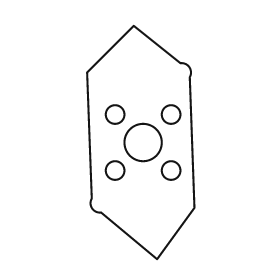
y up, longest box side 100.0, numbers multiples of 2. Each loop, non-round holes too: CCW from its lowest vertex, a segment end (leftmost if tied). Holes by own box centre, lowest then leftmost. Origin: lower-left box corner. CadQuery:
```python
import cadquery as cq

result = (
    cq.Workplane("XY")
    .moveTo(30.0, 0.0)
    .lineTo(46.0, 22.0)
    .lineTo(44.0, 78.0)
    .threePointArc((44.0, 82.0), (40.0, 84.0))
    .lineTo(20.0, 100.0)
    .lineTo(0.0, 80.0)
    .lineTo(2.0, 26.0)
    .threePointArc((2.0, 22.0), (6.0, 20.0))
    .close()
    .moveTo(12.0, 38.0)
    .circle(4.0)
    .moveTo(36.0, 38.0)
    .circle(4.0)
    .moveTo(24.0, 50.0)
    .circle(8.0)
    .moveTo(12.0, 62.0)
    .circle(4.0)
    .moveTo(36.0, 62.0)
    .circle(4.0)
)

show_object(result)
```